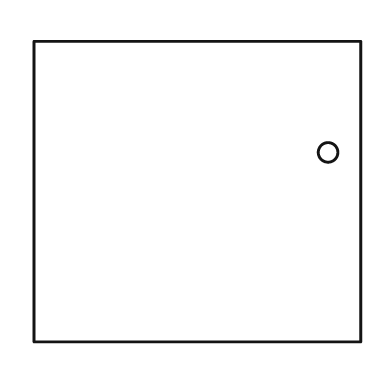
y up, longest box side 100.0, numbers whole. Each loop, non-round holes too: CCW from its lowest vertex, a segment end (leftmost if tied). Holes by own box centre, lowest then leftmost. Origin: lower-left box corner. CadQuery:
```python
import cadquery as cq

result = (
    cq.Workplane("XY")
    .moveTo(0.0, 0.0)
    .lineTo(100.0, 0.0)
    .lineTo(100.0, 92.0)
    .lineTo(0.0, 92.0)
    .close()
    .moveTo(90.0, 58.0)
    .circle(3.0)
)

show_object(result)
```